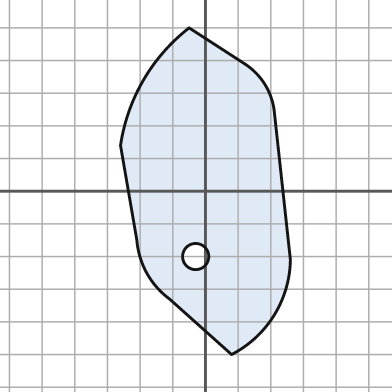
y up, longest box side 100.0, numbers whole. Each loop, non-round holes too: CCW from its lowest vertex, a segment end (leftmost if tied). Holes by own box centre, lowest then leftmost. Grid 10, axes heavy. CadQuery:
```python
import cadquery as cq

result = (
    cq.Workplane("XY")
    .moveTo(8.0, -50.0)
    .threePointArc((21.0, -38.0), (26.0, -21.0))
    .lineTo(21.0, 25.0)
    .threePointArc((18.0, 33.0), (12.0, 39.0))
    .lineTo(-5.0, 50.0)
    .threePointArc((-19.0, 34.0), (-26.0, 14.0))
    .lineTo(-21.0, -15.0)
    .threePointArc((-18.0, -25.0), (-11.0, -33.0))
    .close()
    .moveTo(-3.0, -20.0)
    .circle(4.0)
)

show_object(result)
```